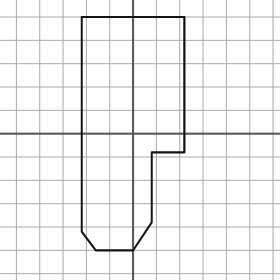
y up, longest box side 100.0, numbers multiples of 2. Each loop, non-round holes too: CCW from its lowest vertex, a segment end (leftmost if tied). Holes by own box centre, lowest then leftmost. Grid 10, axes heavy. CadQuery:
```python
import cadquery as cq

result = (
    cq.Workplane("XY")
    .moveTo(-16.0, -50.0)
    .lineTo(0.0, -50.0)
    .lineTo(8.0, -38.0)
    .lineTo(8.0, -8.0)
    .lineTo(22.0, -8.0)
    .lineTo(22.0, 50.0)
    .lineTo(-22.0, 50.0)
    .lineTo(-22.0, -42.0)
    .close()
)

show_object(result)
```